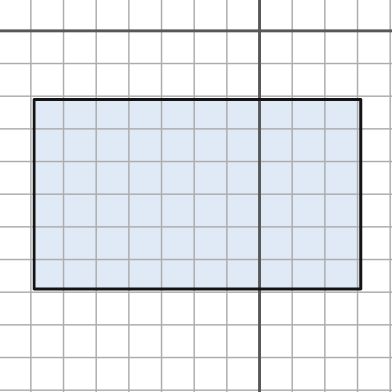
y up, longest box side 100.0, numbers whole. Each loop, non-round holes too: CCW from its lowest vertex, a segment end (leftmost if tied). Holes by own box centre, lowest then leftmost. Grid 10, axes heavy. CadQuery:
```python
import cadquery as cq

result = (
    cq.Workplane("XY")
    .moveTo(-69.0, -79.0)
    .lineTo(31.0, -79.0)
    .lineTo(31.0, -21.0)
    .lineTo(-69.0, -21.0)
    .close()
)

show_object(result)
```